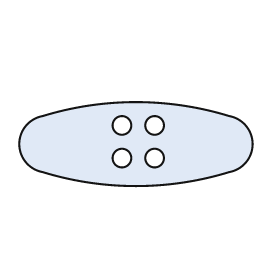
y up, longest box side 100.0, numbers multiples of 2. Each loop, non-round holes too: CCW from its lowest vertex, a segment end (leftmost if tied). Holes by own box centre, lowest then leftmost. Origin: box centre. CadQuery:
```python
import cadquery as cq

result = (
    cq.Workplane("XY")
    .moveTo(-40.0, -12.0)
    .threePointArc((0.0, -18.0), (40.0, -12.0))
    .threePointArc((50.0, 0.0), (40.0, 12.0))
    .threePointArc((0.0, 18.0), (-40.0, 12.0))
    .threePointArc((-50.0, 0.0), (-40.0, -12.0))
    .close()
    .moveTo(-6.0, -6.0)
    .circle(4.0)
    .moveTo(8.0, -6.0)
    .circle(4.0)
    .moveTo(-6.0, 8.0)
    .circle(4.0)
    .moveTo(8.0, 8.0)
    .circle(4.0)
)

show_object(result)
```